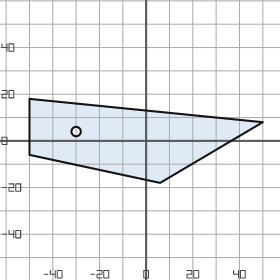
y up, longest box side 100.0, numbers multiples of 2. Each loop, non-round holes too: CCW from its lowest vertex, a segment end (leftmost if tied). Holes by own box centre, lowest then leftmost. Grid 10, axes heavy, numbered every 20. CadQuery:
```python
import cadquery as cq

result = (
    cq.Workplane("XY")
    .moveTo(6.0, -18.0)
    .lineTo(50.0, 8.0)
    .lineTo(-50.0, 18.0)
    .lineTo(-50.0, -6.0)
    .close()
    .moveTo(-30.0, 4.0)
    .circle(2.0)
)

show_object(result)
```